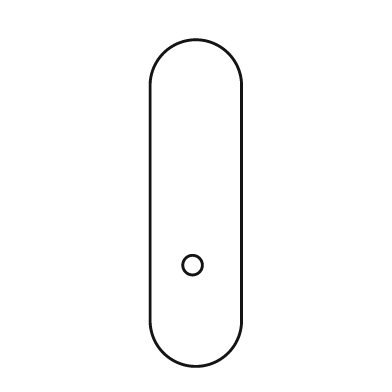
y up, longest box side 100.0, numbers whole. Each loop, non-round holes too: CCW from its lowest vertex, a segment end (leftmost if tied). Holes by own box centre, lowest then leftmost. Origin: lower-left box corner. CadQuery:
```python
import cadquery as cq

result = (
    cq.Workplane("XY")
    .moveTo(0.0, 14.0)
    .threePointArc((14.0, 0.0), (28.0, 14.0))
    .lineTo(28.0, 86.0)
    .threePointArc((14.0, 100.0), (0.0, 86.0))
    .close()
    .moveTo(13.0, 31.0)
    .circle(3.0)
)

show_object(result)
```